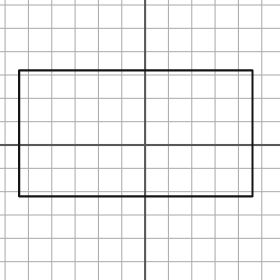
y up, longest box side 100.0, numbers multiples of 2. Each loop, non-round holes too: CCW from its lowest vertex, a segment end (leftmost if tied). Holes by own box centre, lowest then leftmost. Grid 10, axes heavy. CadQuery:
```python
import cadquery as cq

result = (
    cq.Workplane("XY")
    .moveTo(-54.0, -22.0)
    .lineTo(46.0, -22.0)
    .lineTo(46.0, 32.0)
    .lineTo(-54.0, 32.0)
    .close()
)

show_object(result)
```